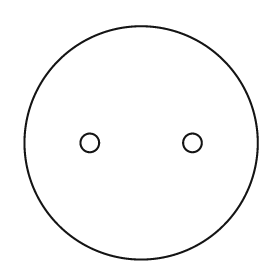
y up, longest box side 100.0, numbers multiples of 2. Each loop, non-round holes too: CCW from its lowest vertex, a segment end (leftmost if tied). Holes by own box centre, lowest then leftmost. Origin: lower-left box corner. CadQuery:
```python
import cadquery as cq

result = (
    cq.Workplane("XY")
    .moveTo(50.0, 50.0)
    .circle(50.0)
    .moveTo(28.0, 50.0)
    .circle(4.0)
    .moveTo(72.0, 50.0)
    .circle(4.0)
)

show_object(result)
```